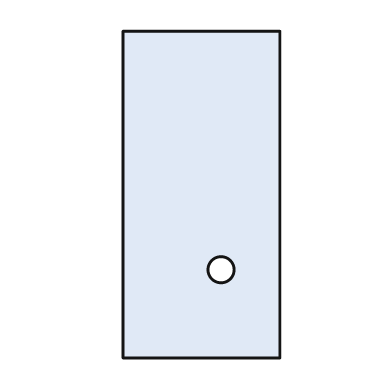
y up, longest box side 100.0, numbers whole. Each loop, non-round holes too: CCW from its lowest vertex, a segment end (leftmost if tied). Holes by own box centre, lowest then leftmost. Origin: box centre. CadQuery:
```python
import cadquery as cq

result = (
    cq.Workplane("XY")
    .moveTo(-24.0, -50.0)
    .lineTo(24.0, -50.0)
    .lineTo(24.0, 50.0)
    .lineTo(-24.0, 50.0)
    .close()
    .moveTo(6.0, -23.0)
    .circle(4.0)
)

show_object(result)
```